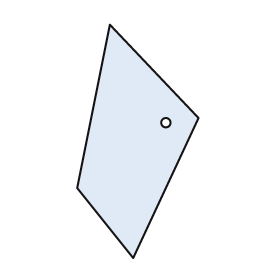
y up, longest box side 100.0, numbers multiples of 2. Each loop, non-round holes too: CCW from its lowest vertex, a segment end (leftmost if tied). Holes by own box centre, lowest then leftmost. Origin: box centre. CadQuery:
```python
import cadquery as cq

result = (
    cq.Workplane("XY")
    .moveTo(-2.0, -50.0)
    .lineTo(26.0, 10.0)
    .lineTo(-12.0, 50.0)
    .lineTo(-26.0, -20.0)
    .close()
    .moveTo(12.0, 8.0)
    .circle(2.0)
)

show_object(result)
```